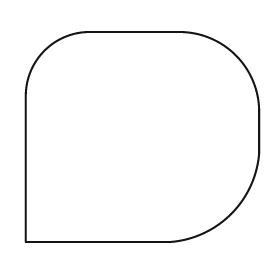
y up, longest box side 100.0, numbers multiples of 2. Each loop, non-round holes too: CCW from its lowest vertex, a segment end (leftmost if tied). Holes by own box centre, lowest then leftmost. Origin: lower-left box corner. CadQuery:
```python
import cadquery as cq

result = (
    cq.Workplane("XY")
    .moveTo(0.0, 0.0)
    .lineTo(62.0, 0.0)
    .threePointArc((88.0, 12.0), (100.0, 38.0))
    .lineTo(100.0, 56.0)
    .threePointArc((90.0, 80.0), (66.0, 90.0))
    .lineTo(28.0, 90.0)
    .threePointArc((8.0, 82.0), (0.0, 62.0))
    .close()
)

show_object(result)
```